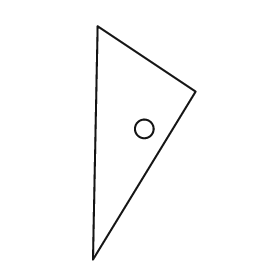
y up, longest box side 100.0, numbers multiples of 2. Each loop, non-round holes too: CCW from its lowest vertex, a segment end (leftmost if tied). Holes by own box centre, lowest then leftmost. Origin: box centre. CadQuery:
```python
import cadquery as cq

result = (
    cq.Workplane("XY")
    .moveTo(-22.0, -50.0)
    .lineTo(22.0, 22.0)
    .lineTo(-20.0, 50.0)
    .close()
    .moveTo(0.0, 6.0)
    .circle(4.0)
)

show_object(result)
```